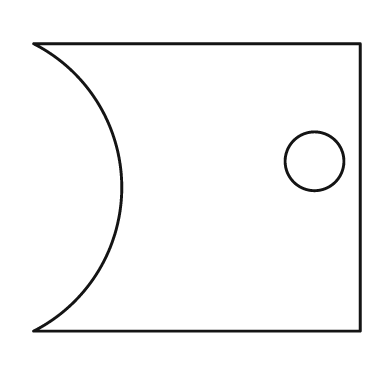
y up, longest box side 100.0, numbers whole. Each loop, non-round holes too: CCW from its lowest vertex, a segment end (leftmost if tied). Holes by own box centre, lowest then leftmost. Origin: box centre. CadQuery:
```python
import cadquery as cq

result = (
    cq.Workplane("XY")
    .moveTo(-50.0, -44.0)
    .lineTo(50.0, -44.0)
    .lineTo(50.0, 44.0)
    .lineTo(-50.0, 44.0)
    .threePointArc((-23.0, 0.0), (-50.0, -44.0))
    .close()
    .moveTo(36.0, 8.0)
    .circle(9.0)
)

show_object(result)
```